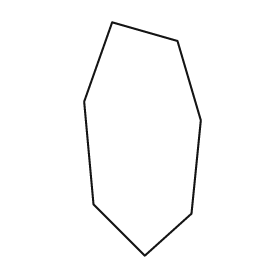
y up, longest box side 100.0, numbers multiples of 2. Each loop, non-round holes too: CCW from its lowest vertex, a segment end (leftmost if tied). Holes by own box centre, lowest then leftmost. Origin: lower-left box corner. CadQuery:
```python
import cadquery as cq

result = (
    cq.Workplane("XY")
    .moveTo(26.0, 0.0)
    .lineTo(46.0, 18.0)
    .lineTo(50.0, 58.0)
    .lineTo(40.0, 92.0)
    .lineTo(12.0, 100.0)
    .lineTo(0.0, 66.0)
    .lineTo(4.0, 22.0)
    .close()
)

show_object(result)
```